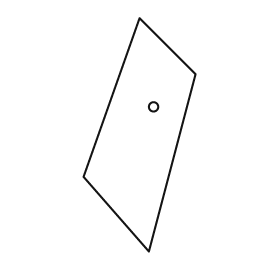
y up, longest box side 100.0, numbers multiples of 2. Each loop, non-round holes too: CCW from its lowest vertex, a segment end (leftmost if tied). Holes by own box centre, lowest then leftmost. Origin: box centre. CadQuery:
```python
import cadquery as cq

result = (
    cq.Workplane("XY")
    .moveTo(4.0, -50.0)
    .lineTo(24.0, 26.0)
    .lineTo(0.0, 50.0)
    .lineTo(-24.0, -18.0)
    .close()
    .moveTo(6.0, 12.0)
    .circle(2.0)
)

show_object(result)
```